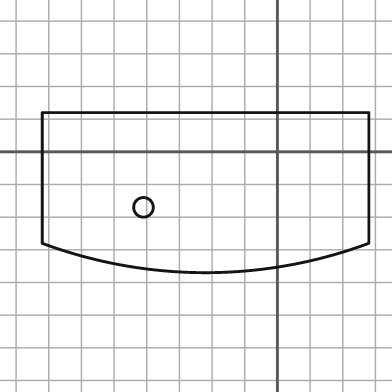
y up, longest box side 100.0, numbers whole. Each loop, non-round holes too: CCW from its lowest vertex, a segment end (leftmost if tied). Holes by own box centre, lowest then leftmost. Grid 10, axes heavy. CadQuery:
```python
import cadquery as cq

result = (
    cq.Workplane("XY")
    .moveTo(-72.0, -28.0)
    .threePointArc((-22.0, -37.0), (28.0, -28.0))
    .lineTo(28.0, 12.0)
    .lineTo(-72.0, 12.0)
    .close()
    .moveTo(-41.0, -17.0)
    .circle(3.0)
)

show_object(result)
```